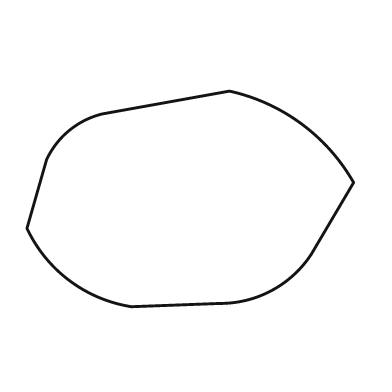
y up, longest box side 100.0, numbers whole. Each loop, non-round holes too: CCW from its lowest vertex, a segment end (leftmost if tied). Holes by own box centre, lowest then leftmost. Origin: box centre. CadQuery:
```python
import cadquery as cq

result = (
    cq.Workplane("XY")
    .moveTo(-18.0, -33.0)
    .lineTo(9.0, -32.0)
    .threePointArc((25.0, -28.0), (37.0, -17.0))
    .lineTo(50.0, 5.0)
    .threePointArc((34.0, 23.0), (12.0, 33.0))
    .lineTo(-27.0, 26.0)
    .threePointArc((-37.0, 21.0), (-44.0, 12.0))
    .lineTo(-50.0, -9.0)
    .threePointArc((-37.0, -25.0), (-18.0, -33.0))
    .close()
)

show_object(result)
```